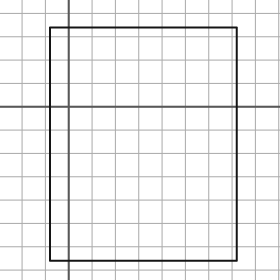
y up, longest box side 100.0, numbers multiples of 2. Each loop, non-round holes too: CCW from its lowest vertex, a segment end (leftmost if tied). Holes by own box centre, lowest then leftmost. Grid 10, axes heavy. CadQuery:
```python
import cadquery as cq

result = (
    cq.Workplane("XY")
    .moveTo(-8.0, -66.0)
    .lineTo(72.0, -66.0)
    .lineTo(72.0, 34.0)
    .lineTo(-8.0, 34.0)
    .close()
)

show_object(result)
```